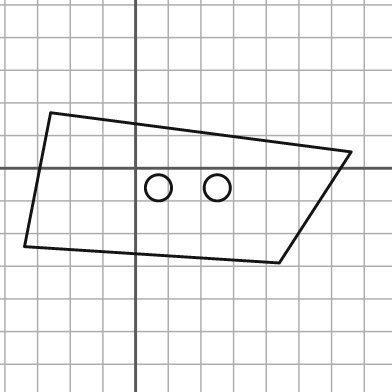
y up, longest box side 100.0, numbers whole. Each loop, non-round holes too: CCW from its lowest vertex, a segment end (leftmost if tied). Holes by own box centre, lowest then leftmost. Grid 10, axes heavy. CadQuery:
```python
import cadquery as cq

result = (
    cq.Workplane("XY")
    .moveTo(44.0, -29.0)
    .lineTo(66.0, 5.0)
    .lineTo(-26.0, 17.0)
    .lineTo(-34.0, -24.0)
    .close()
    .moveTo(7.0, -6.0)
    .circle(4.0)
    .moveTo(25.0, -6.0)
    .circle(4.0)
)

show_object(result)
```